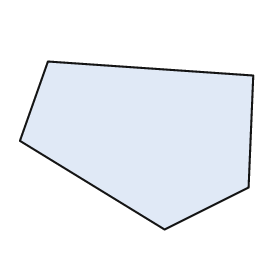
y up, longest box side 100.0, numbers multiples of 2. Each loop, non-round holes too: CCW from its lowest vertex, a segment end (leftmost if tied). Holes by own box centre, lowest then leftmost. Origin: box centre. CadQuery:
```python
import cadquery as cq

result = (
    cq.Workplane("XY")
    .moveTo(12.0, -36.0)
    .lineTo(48.0, -18.0)
    .lineTo(50.0, 30.0)
    .lineTo(-38.0, 36.0)
    .lineTo(-50.0, 2.0)
    .close()
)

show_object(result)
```